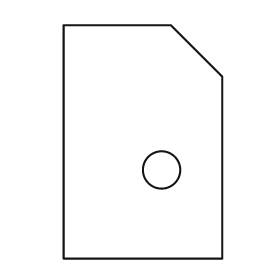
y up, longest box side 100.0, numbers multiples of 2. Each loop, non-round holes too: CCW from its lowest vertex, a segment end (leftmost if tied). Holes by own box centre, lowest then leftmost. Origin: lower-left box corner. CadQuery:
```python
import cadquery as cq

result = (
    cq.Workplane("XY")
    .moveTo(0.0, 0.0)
    .lineTo(68.0, 0.0)
    .lineTo(68.0, 78.0)
    .lineTo(46.0, 100.0)
    .lineTo(0.0, 100.0)
    .close()
    .moveTo(42.0, 38.0)
    .circle(8.0)
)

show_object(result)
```